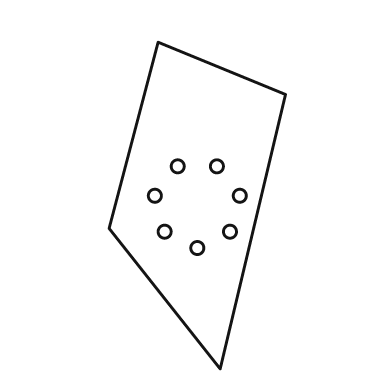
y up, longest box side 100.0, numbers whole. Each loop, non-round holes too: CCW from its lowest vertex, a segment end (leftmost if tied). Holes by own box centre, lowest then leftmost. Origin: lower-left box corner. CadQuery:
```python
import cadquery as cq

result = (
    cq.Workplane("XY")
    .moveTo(34.0, 0.0)
    .lineTo(54.0, 84.0)
    .lineTo(15.0, 100.0)
    .lineTo(0.0, 43.0)
    .close()
    .moveTo(27.0, 37.0)
    .circle(2.0)
    .moveTo(17.0, 42.0)
    .circle(2.0)
    .moveTo(37.0, 42.0)
    .circle(2.0)
    .moveTo(14.0, 53.0)
    .circle(2.0)
    .moveTo(40.0, 53.0)
    .circle(2.0)
    .moveTo(21.0, 62.0)
    .circle(2.0)
    .moveTo(33.0, 62.0)
    .circle(2.0)
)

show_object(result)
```